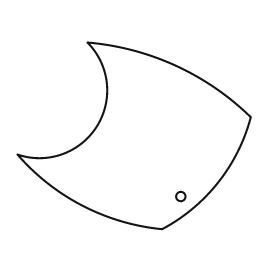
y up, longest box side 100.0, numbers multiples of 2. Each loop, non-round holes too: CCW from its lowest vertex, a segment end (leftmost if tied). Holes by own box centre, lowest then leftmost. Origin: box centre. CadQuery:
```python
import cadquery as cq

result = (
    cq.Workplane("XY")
    .moveTo(12.0, -40.0)
    .threePointArc((36.0, -20.0), (50.0, 8.0))
    .threePointArc((18.0, 30.0), (-20.0, 40.0))
    .threePointArc((-16.0, 4.0), (-50.0, -8.0))
    .threePointArc((-22.0, -30.0), (12.0, -40.0))
    .close()
    .moveTo(20.0, -26.0)
    .circle(2.0)
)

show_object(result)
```